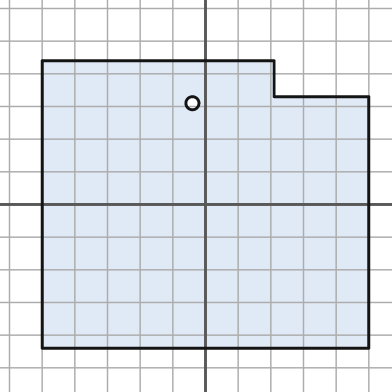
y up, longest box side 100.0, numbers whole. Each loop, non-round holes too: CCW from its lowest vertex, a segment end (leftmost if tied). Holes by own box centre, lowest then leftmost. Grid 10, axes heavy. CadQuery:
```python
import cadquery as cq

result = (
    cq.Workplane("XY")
    .moveTo(-50.0, -44.0)
    .lineTo(50.0, -44.0)
    .lineTo(50.0, 33.0)
    .lineTo(21.0, 33.0)
    .lineTo(21.0, 44.0)
    .lineTo(-50.0, 44.0)
    .close()
    .moveTo(-4.0, 31.0)
    .circle(2.0)
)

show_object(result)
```